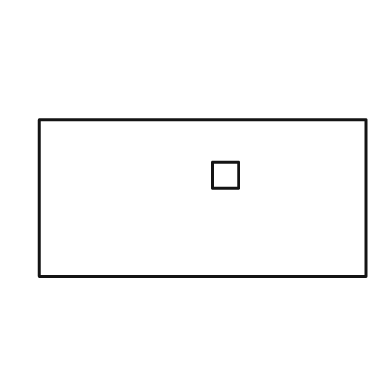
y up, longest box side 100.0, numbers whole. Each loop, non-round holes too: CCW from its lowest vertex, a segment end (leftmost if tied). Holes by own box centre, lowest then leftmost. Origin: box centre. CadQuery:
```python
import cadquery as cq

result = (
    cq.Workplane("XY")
    .moveTo(-50.0, -24.0)
    .lineTo(50.0, -24.0)
    .lineTo(50.0, 24.0)
    .lineTo(-50.0, 24.0)
    .close()
    .moveTo(3.0, 3.0)
    .lineTo(11.0, 3.0)
    .lineTo(11.0, 11.0)
    .lineTo(3.0, 11.0)
    .close()
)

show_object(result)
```